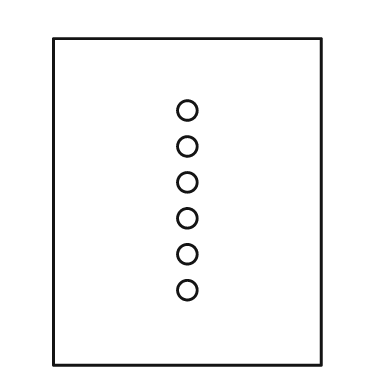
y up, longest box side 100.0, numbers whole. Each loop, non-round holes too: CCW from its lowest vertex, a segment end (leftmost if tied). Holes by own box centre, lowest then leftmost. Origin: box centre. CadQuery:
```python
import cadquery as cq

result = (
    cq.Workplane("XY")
    .moveTo(-41.0, -50.0)
    .lineTo(41.0, -50.0)
    .lineTo(41.0, 50.0)
    .lineTo(-41.0, 50.0)
    .close()
    .moveTo(0.0, -27.0)
    .circle(3.0)
    .moveTo(0.0, -16.0)
    .circle(3.0)
    .moveTo(0.0, -5.0)
    .circle(3.0)
    .moveTo(0.0, 6.0)
    .circle(3.0)
    .moveTo(0.0, 17.0)
    .circle(3.0)
    .moveTo(0.0, 28.0)
    .circle(3.0)
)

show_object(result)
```